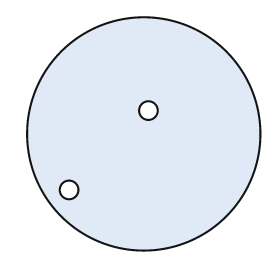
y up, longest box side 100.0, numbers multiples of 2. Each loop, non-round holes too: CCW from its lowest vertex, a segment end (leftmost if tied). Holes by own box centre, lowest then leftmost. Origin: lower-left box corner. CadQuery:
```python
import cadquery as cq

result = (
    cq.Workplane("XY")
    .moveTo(50.0, 50.0)
    .circle(50.0)
    .moveTo(18.0, 26.0)
    .circle(4.0)
    .moveTo(52.0, 60.0)
    .circle(4.0)
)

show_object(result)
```